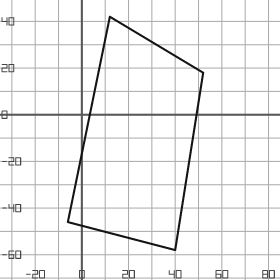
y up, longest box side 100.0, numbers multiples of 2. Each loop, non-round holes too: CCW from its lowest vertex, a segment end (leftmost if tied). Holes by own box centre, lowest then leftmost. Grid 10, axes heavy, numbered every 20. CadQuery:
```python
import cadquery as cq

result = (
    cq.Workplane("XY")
    .moveTo(40.0, -58.0)
    .lineTo(52.0, 18.0)
    .lineTo(12.0, 42.0)
    .lineTo(-6.0, -46.0)
    .close()
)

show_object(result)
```